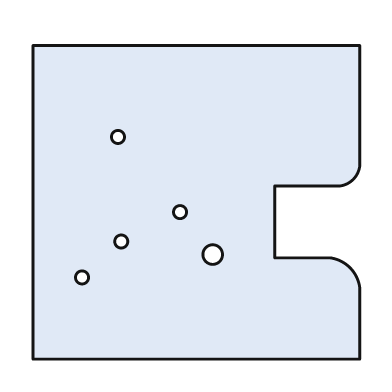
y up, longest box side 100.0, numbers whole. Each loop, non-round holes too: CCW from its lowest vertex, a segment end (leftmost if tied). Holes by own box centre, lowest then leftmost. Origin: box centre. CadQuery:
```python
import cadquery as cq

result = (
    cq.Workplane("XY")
    .moveTo(-50.0, -48.0)
    .lineTo(50.0, -48.0)
    .lineTo(50.0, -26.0)
    .threePointArc((47.0, -20.0), (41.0, -17.0))
    .lineTo(24.0, -17.0)
    .lineTo(24.0, 5.0)
    .lineTo(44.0, 5.0)
    .threePointArc((48.0, 7.0), (50.0, 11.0))
    .lineTo(50.0, 48.0)
    .lineTo(-50.0, 48.0)
    .close()
    .moveTo(-35.0, -23.0)
    .circle(2.0)
    .moveTo(5.0, -16.0)
    .circle(3.0)
    .moveTo(-23.0, -12.0)
    .circle(2.0)
    .moveTo(-5.0, -3.0)
    .circle(2.0)
    .moveTo(-24.0, 20.0)
    .circle(2.0)
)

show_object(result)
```